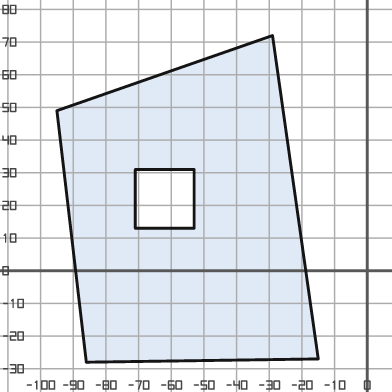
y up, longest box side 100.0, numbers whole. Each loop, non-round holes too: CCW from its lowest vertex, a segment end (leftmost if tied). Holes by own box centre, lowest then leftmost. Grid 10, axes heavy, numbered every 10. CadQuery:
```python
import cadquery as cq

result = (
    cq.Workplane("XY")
    .moveTo(-86.0, -28.0)
    .lineTo(-15.0, -27.0)
    .lineTo(-29.0, 72.0)
    .lineTo(-95.0, 49.0)
    .close()
    .moveTo(-71.0, 13.0)
    .lineTo(-53.0, 13.0)
    .lineTo(-53.0, 31.0)
    .lineTo(-71.0, 31.0)
    .close()
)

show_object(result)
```